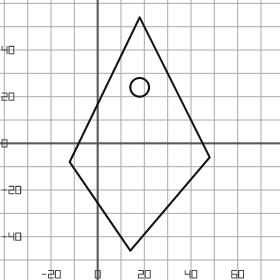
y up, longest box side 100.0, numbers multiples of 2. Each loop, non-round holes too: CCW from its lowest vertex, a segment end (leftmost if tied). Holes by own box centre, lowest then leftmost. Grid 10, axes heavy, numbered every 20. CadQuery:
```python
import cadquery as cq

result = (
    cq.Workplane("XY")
    .moveTo(14.0, -46.0)
    .lineTo(48.0, -6.0)
    .lineTo(18.0, 54.0)
    .lineTo(-12.0, -8.0)
    .close()
    .moveTo(18.0, 24.0)
    .circle(4.0)
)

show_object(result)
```